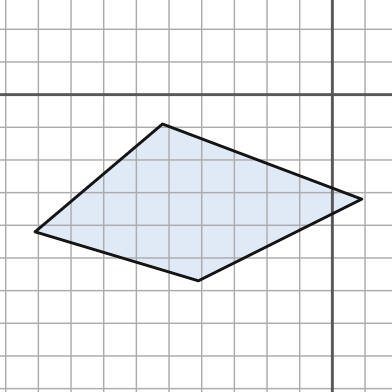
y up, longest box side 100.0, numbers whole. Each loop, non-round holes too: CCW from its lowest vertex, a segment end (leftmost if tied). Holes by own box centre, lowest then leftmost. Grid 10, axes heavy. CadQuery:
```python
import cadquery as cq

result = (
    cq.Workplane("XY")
    .moveTo(-41.0, -57.0)
    .lineTo(9.0, -32.0)
    .lineTo(-52.0, -9.0)
    .lineTo(-91.0, -42.0)
    .close()
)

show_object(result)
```